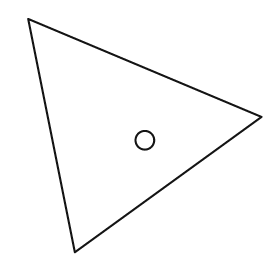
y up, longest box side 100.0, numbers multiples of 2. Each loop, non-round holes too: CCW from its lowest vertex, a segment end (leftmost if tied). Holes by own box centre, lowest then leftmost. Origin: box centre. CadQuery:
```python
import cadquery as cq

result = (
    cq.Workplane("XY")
    .moveTo(-30.0, -50.0)
    .lineTo(50.0, 8.0)
    .lineTo(-50.0, 50.0)
    .close()
    .moveTo(0.0, -2.0)
    .circle(4.0)
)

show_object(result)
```